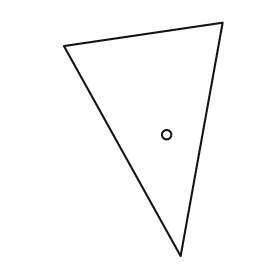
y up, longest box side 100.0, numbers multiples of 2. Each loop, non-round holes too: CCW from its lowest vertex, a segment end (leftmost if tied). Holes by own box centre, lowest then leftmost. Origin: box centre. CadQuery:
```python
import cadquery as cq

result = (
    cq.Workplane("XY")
    .moveTo(16.0, -50.0)
    .lineTo(34.0, 50.0)
    .lineTo(-34.0, 40.0)
    .close()
    .moveTo(10.0, 2.0)
    .circle(2.0)
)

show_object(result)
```